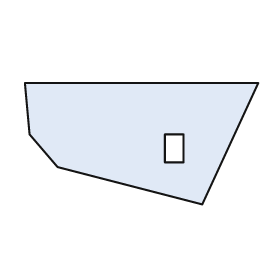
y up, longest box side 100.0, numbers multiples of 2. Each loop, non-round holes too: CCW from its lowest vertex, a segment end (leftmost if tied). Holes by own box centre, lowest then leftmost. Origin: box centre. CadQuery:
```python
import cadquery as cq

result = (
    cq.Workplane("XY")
    .moveTo(26.0, -26.0)
    .lineTo(50.0, 26.0)
    .lineTo(-50.0, 26.0)
    .lineTo(-48.0, 4.0)
    .lineTo(-36.0, -10.0)
    .close()
    .moveTo(10.0, -8.0)
    .lineTo(18.0, -8.0)
    .lineTo(18.0, 4.0)
    .lineTo(10.0, 4.0)
    .close()
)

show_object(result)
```